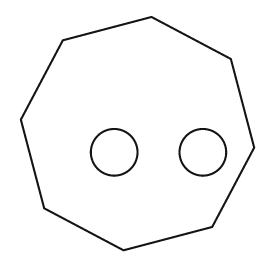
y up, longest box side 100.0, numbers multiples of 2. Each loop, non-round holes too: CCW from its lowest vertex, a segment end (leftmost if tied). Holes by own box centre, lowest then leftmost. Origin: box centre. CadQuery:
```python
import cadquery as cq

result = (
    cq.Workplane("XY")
    .moveTo(-6.0, -50.0)
    .lineTo(32.0, -40.0)
    .lineTo(50.0, -6.0)
    .lineTo(40.0, 32.0)
    .lineTo(6.0, 50.0)
    .lineTo(-32.0, 40.0)
    .lineTo(-50.0, 6.0)
    .lineTo(-40.0, -32.0)
    .close()
    .moveTo(-10.0, -8.0)
    .circle(10.0)
    .moveTo(28.0, -8.0)
    .circle(10.0)
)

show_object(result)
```